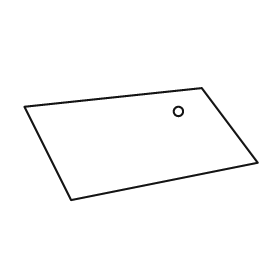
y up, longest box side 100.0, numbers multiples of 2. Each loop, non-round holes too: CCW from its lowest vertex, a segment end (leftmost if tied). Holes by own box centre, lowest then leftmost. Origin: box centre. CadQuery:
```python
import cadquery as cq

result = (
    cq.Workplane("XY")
    .moveTo(-30.0, -24.0)
    .lineTo(50.0, -8.0)
    .lineTo(26.0, 24.0)
    .lineTo(-50.0, 16.0)
    .close()
    .moveTo(16.0, 14.0)
    .circle(2.0)
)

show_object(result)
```